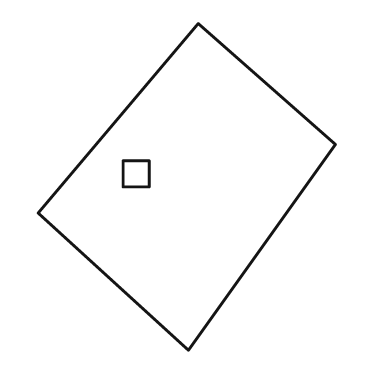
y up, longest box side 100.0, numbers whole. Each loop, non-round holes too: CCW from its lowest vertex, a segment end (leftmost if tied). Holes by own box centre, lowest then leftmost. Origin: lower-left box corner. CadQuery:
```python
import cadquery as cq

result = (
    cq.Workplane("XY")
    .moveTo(46.0, 0.0)
    .lineTo(91.0, 63.0)
    .lineTo(49.0, 100.0)
    .lineTo(0.0, 42.0)
    .close()
    .moveTo(26.0, 50.0)
    .lineTo(34.0, 50.0)
    .lineTo(34.0, 58.0)
    .lineTo(26.0, 58.0)
    .close()
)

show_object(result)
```